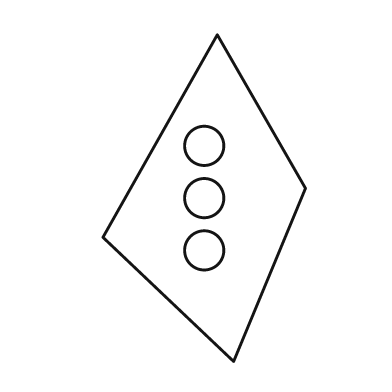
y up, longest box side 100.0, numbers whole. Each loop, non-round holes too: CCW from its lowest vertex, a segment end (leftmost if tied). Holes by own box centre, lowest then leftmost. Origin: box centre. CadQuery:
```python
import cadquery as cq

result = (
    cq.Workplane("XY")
    .moveTo(9.0, -50.0)
    .lineTo(31.0, 3.0)
    .lineTo(4.0, 50.0)
    .lineTo(-31.0, -12.0)
    .close()
    .moveTo(0.0, -16.0)
    .circle(6.0)
    .moveTo(0.0, 0.0)
    .circle(6.0)
    .moveTo(0.0, 16.0)
    .circle(6.0)
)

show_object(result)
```